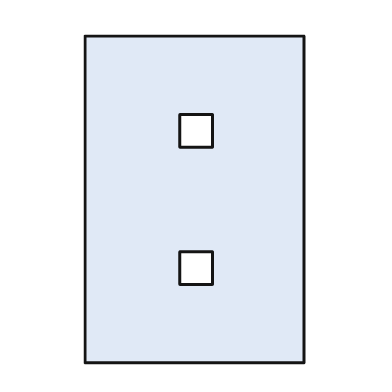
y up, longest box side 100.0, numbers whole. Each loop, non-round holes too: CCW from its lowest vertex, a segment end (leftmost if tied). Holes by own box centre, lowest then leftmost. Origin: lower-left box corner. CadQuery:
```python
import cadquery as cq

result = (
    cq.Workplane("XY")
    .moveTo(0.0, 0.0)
    .lineTo(67.0, 0.0)
    .lineTo(67.0, 100.0)
    .lineTo(0.0, 100.0)
    .close()
    .moveTo(29.0, 24.0)
    .lineTo(39.0, 24.0)
    .lineTo(39.0, 34.0)
    .lineTo(29.0, 34.0)
    .close()
    .moveTo(29.0, 66.0)
    .lineTo(39.0, 66.0)
    .lineTo(39.0, 76.0)
    .lineTo(29.0, 76.0)
    .close()
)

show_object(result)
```